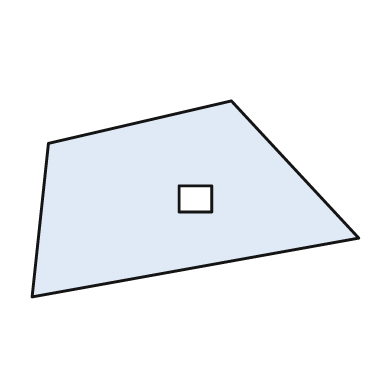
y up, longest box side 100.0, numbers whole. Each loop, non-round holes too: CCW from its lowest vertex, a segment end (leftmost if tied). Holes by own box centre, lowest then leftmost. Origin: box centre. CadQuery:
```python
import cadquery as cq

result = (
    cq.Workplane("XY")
    .moveTo(-50.0, -30.0)
    .lineTo(50.0, -12.0)
    .lineTo(11.0, 30.0)
    .lineTo(-45.0, 17.0)
    .close()
    .moveTo(-5.0, -4.0)
    .lineTo(5.0, -4.0)
    .lineTo(5.0, 4.0)
    .lineTo(-5.0, 4.0)
    .close()
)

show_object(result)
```